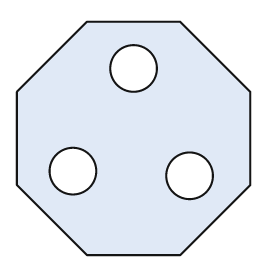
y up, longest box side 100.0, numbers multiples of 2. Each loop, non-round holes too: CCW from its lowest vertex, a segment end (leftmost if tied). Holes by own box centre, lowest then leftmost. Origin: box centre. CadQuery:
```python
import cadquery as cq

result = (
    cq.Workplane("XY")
    .moveTo(-20.0, -50.0)
    .lineTo(20.0, -50.0)
    .lineTo(50.0, -20.0)
    .lineTo(50.0, 20.0)
    .lineTo(20.0, 50.0)
    .lineTo(-20.0, 50.0)
    .lineTo(-50.0, 20.0)
    .lineTo(-50.0, -20.0)
    .close()
    .moveTo(24.0, -16.0)
    .circle(10.0)
    .moveTo(-26.0, -14.0)
    .circle(10.0)
    .moveTo(0.0, 30.0)
    .circle(10.0)
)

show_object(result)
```